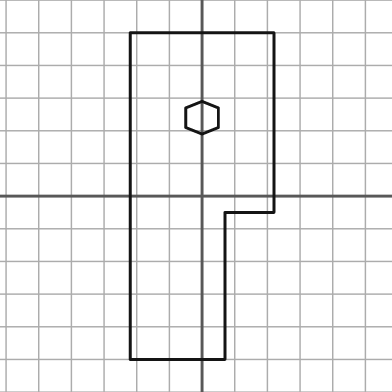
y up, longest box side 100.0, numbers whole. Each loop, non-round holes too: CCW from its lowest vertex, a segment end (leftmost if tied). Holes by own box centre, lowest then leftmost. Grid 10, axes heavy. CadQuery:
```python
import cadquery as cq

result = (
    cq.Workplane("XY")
    .moveTo(-22.0, -50.0)
    .lineTo(7.0, -50.0)
    .lineTo(7.0, -5.0)
    .lineTo(22.0, -5.0)
    .lineTo(22.0, 50.0)
    .lineTo(-22.0, 50.0)
    .close()
    .moveTo(0.0, 19.0)
    .lineTo(5.0, 21.0)
    .lineTo(5.0, 27.0)
    .lineTo(0.0, 29.0)
    .lineTo(-5.0, 27.0)
    .lineTo(-5.0, 21.0)
    .close()
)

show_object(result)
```